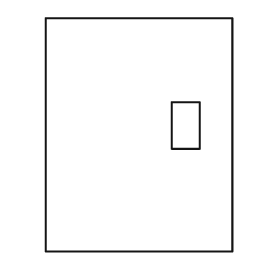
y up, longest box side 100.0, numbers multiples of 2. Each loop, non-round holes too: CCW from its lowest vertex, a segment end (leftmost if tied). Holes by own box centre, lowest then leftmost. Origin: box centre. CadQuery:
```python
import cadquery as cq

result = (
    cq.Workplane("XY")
    .moveTo(-40.0, -50.0)
    .lineTo(40.0, -50.0)
    .lineTo(40.0, 50.0)
    .lineTo(-40.0, 50.0)
    .close()
    .moveTo(14.0, -6.0)
    .lineTo(26.0, -6.0)
    .lineTo(26.0, 14.0)
    .lineTo(14.0, 14.0)
    .close()
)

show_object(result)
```